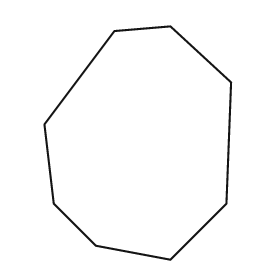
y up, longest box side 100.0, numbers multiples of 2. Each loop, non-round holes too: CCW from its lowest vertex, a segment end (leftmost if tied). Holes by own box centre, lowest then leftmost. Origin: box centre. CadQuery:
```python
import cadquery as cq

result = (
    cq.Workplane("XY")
    .moveTo(14.0, -50.0)
    .lineTo(38.0, -26.0)
    .lineTo(40.0, 26.0)
    .lineTo(14.0, 50.0)
    .lineTo(-10.0, 48.0)
    .lineTo(-40.0, 8.0)
    .lineTo(-36.0, -26.0)
    .lineTo(-18.0, -44.0)
    .close()
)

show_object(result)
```